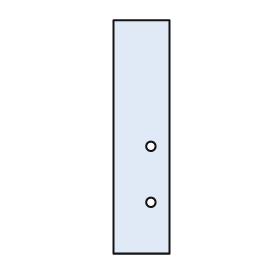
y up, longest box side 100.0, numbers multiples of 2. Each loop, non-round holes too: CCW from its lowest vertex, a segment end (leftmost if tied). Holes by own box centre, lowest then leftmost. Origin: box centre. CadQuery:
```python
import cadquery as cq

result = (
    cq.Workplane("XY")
    .moveTo(-12.0, -50.0)
    .lineTo(12.0, -50.0)
    .lineTo(12.0, 50.0)
    .lineTo(-12.0, 50.0)
    .close()
    .moveTo(4.0, -28.0)
    .circle(2.0)
    .moveTo(4.0, -4.0)
    .circle(2.0)
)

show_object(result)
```